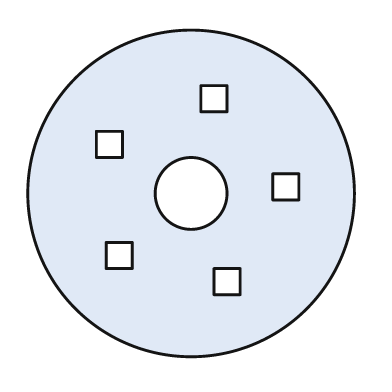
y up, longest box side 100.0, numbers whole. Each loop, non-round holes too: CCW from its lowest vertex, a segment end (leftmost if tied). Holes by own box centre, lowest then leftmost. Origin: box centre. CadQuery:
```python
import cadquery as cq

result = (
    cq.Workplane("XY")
    .moveTo(0.0, 0.0)
    .circle(50.0)
    .moveTo(7.0, -31.0)
    .lineTo(15.0, -31.0)
    .lineTo(15.0, -23.0)
    .lineTo(7.0, -23.0)
    .close()
    .moveTo(-26.0, -23.0)
    .lineTo(-18.0, -23.0)
    .lineTo(-18.0, -15.0)
    .lineTo(-26.0, -15.0)
    .close()
    .moveTo(0.0, 0.0)
    .circle(11.0)
    .moveTo(25.0, -2.0)
    .lineTo(33.0, -2.0)
    .lineTo(33.0, 6.0)
    .lineTo(25.0, 6.0)
    .close()
    .moveTo(-29.0, 11.0)
    .lineTo(-21.0, 11.0)
    .lineTo(-21.0, 19.0)
    .lineTo(-29.0, 19.0)
    .close()
    .moveTo(3.0, 25.0)
    .lineTo(11.0, 25.0)
    .lineTo(11.0, 33.0)
    .lineTo(3.0, 33.0)
    .close()
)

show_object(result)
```